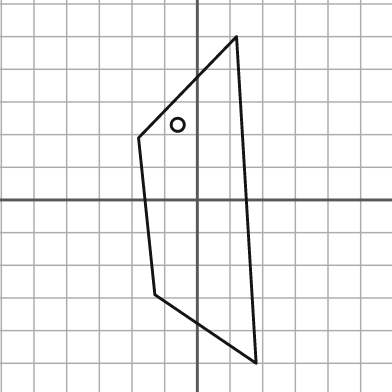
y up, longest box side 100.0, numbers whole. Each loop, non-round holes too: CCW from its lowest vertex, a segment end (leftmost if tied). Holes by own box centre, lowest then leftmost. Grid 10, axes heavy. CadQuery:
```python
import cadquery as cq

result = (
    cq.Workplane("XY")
    .moveTo(18.0, -50.0)
    .lineTo(12.0, 50.0)
    .lineTo(-18.0, 19.0)
    .lineTo(-13.0, -29.0)
    .close()
    .moveTo(-6.0, 23.0)
    .circle(2.0)
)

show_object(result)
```